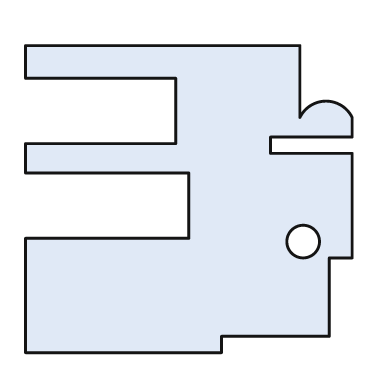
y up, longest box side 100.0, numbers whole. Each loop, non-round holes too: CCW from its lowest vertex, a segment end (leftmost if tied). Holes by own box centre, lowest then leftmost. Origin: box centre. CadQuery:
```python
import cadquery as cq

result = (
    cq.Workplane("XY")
    .moveTo(-50.0, -47.0)
    .lineTo(10.0, -47.0)
    .lineTo(10.0, -42.0)
    .lineTo(43.0, -42.0)
    .lineTo(43.0, -18.0)
    .lineTo(50.0, -18.0)
    .lineTo(50.0, 14.0)
    .lineTo(25.0, 14.0)
    .lineTo(25.0, 19.0)
    .lineTo(50.0, 19.0)
    .lineTo(50.0, 25.0)
    .threePointArc((42.0, 30.0), (34.0, 25.0))
    .lineTo(34.0, 47.0)
    .lineTo(-50.0, 47.0)
    .lineTo(-50.0, 37.0)
    .lineTo(-4.0, 37.0)
    .lineTo(-4.0, 17.0)
    .lineTo(-50.0, 17.0)
    .lineTo(-50.0, 8.0)
    .lineTo(0.0, 8.0)
    .lineTo(0.0, -12.0)
    .lineTo(-50.0, -12.0)
    .close()
    .moveTo(35.0, -13.0)
    .circle(5.0)
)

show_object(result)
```